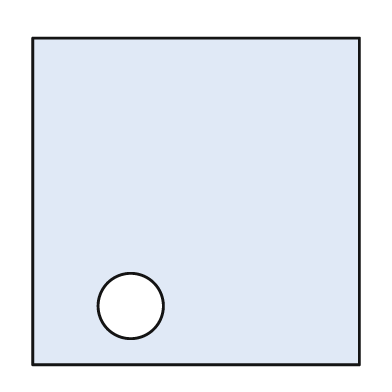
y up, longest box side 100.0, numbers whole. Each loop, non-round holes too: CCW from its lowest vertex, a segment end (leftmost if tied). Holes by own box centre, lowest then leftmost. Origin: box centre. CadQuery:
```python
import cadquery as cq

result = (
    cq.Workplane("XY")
    .moveTo(-50.0, -50.0)
    .lineTo(50.0, -50.0)
    .lineTo(50.0, 50.0)
    .lineTo(-50.0, 50.0)
    .close()
    .moveTo(-20.0, -32.0)
    .circle(10.0)
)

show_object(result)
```